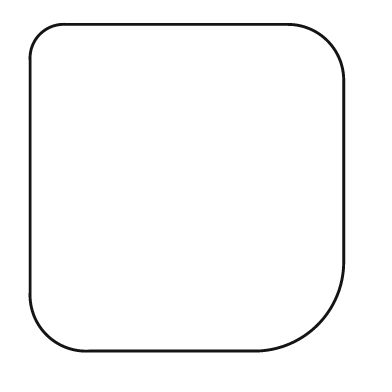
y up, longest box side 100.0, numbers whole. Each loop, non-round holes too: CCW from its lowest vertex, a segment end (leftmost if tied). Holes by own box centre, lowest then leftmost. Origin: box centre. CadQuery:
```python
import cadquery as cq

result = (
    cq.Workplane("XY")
    .moveTo(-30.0, -50.0)
    .lineTo(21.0, -50.0)
    .threePointArc((40.0, -42.0), (48.0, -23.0))
    .lineTo(48.0, 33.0)
    .threePointArc((43.0, 45.0), (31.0, 50.0))
    .lineTo(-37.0, 50.0)
    .threePointArc((-45.0, 47.0), (-48.0, 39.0))
    .lineTo(-48.0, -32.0)
    .threePointArc((-43.0, -45.0), (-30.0, -50.0))
    .close()
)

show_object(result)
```